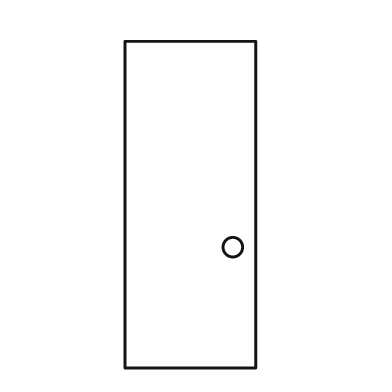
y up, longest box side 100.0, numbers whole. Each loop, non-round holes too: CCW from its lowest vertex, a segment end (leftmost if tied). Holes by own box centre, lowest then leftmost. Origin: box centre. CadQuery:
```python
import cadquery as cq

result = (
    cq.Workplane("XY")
    .moveTo(-20.0, -50.0)
    .lineTo(20.0, -50.0)
    .lineTo(20.0, 50.0)
    .lineTo(-20.0, 50.0)
    .close()
    .moveTo(13.0, -13.0)
    .circle(3.0)
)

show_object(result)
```